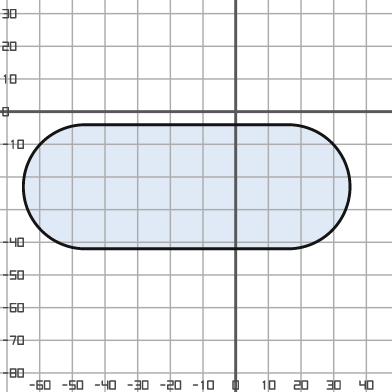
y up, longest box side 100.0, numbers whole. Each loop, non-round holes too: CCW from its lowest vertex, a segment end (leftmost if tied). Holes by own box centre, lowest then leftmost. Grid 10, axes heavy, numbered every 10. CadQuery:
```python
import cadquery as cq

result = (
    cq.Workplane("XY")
    .moveTo(-46.0, -42.0)
    .lineTo(16.0, -42.0)
    .threePointArc((35.0, -23.0), (16.0, -4.0))
    .lineTo(-46.0, -4.0)
    .threePointArc((-65.0, -23.0), (-46.0, -42.0))
    .close()
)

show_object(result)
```